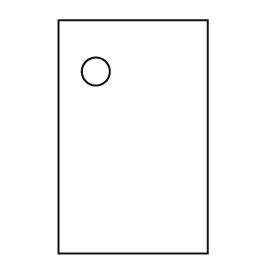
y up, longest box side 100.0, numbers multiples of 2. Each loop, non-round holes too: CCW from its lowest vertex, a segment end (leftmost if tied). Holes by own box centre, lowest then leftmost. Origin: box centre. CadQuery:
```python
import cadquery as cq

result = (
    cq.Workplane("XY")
    .moveTo(-32.0, -50.0)
    .lineTo(32.0, -50.0)
    .lineTo(32.0, 50.0)
    .lineTo(-32.0, 50.0)
    .close()
    .moveTo(-16.0, 28.0)
    .circle(6.0)
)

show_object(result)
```